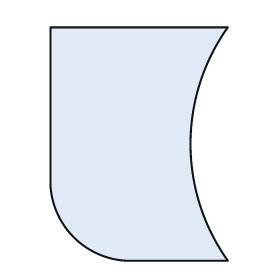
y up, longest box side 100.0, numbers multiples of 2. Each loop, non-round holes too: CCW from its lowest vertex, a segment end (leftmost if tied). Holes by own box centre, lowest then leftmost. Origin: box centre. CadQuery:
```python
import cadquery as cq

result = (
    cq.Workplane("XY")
    .moveTo(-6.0, -50.0)
    .lineTo(38.0, -50.0)
    .threePointArc((22.0, 0.0), (38.0, 50.0))
    .lineTo(-38.0, 50.0)
    .lineTo(-38.0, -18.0)
    .threePointArc((-28.0, -40.0), (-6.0, -50.0))
    .close()
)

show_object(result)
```